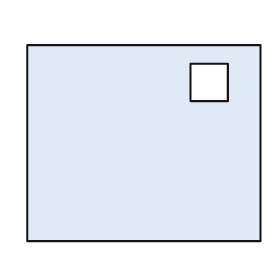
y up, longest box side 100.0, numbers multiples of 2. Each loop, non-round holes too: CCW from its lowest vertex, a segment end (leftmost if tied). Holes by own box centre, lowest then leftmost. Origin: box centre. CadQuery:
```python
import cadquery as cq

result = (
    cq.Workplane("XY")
    .moveTo(-50.0, -42.0)
    .lineTo(50.0, -42.0)
    .lineTo(50.0, 42.0)
    .lineTo(-50.0, 42.0)
    .close()
    .moveTo(20.0, 18.0)
    .lineTo(36.0, 18.0)
    .lineTo(36.0, 34.0)
    .lineTo(20.0, 34.0)
    .close()
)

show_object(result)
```